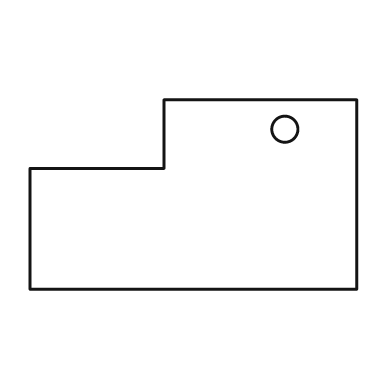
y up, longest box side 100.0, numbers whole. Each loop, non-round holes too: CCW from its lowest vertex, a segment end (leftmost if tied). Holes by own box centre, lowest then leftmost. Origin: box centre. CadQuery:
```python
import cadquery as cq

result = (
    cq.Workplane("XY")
    .moveTo(-50.0, -29.0)
    .lineTo(50.0, -29.0)
    .lineTo(50.0, 29.0)
    .lineTo(-9.0, 29.0)
    .lineTo(-9.0, 8.0)
    .lineTo(-50.0, 8.0)
    .close()
    .moveTo(28.0, 20.0)
    .circle(4.0)
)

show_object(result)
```